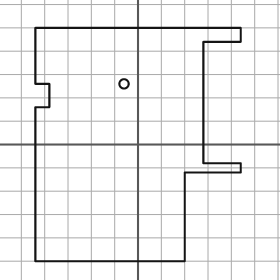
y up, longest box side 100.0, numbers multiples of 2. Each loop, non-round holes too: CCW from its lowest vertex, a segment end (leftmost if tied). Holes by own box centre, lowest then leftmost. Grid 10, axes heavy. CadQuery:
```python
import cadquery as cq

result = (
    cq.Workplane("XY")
    .moveTo(-44.0, -50.0)
    .lineTo(20.0, -50.0)
    .lineTo(20.0, -12.0)
    .lineTo(44.0, -12.0)
    .lineTo(44.0, -8.0)
    .lineTo(28.0, -8.0)
    .lineTo(28.0, 44.0)
    .lineTo(44.0, 44.0)
    .lineTo(44.0, 50.0)
    .lineTo(-44.0, 50.0)
    .lineTo(-44.0, 26.0)
    .lineTo(-38.0, 26.0)
    .lineTo(-38.0, 16.0)
    .lineTo(-44.0, 16.0)
    .close()
    .moveTo(-6.0, 26.0)
    .circle(2.0)
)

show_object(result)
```